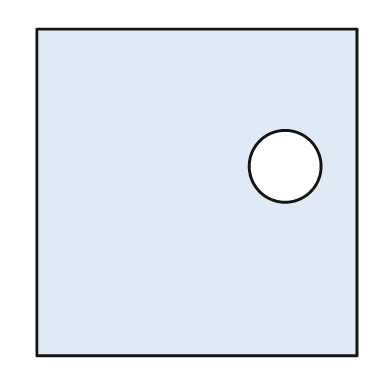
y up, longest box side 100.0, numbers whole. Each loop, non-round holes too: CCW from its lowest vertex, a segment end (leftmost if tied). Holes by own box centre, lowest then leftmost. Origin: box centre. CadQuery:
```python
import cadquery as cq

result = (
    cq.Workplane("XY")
    .moveTo(-49.0, -50.0)
    .lineTo(49.0, -50.0)
    .lineTo(49.0, 50.0)
    .lineTo(-49.0, 50.0)
    .close()
    .moveTo(27.0, 8.0)
    .circle(11.0)
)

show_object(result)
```